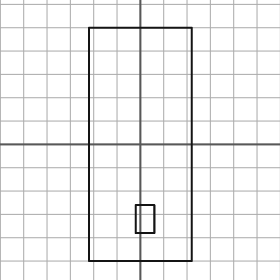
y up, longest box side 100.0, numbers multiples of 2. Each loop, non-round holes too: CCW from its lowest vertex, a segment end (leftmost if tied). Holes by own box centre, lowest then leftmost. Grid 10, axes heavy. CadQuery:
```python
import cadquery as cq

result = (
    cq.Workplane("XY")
    .moveTo(-22.0, -50.0)
    .lineTo(22.0, -50.0)
    .lineTo(22.0, 50.0)
    .lineTo(-22.0, 50.0)
    .close()
    .moveTo(-2.0, -38.0)
    .lineTo(6.0, -38.0)
    .lineTo(6.0, -26.0)
    .lineTo(-2.0, -26.0)
    .close()
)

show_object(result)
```